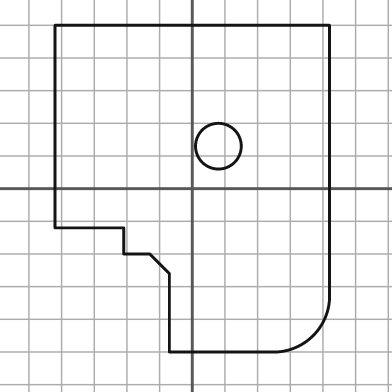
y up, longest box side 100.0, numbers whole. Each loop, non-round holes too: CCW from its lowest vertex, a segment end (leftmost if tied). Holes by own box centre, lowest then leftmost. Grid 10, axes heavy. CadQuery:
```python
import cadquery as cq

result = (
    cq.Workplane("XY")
    .moveTo(-7.0, -50.0)
    .lineTo(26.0, -50.0)
    .threePointArc((37.0, -45.0), (42.0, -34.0))
    .lineTo(42.0, 50.0)
    .lineTo(-42.0, 50.0)
    .lineTo(-42.0, -12.0)
    .lineTo(-21.0, -12.0)
    .lineTo(-21.0, -20.0)
    .lineTo(-13.0, -20.0)
    .lineTo(-7.0, -26.0)
    .close()
    .moveTo(8.0, 13.0)
    .circle(7.0)
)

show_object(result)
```